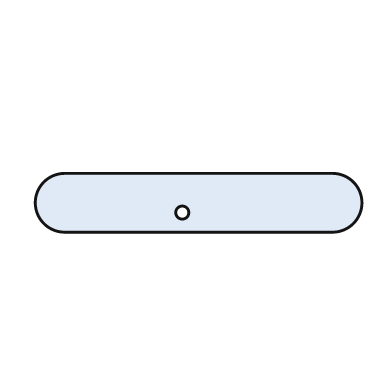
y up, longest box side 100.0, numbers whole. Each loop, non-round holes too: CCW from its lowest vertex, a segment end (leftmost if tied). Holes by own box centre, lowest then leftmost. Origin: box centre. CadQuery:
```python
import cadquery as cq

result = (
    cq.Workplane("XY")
    .moveTo(-41.0, -9.0)
    .lineTo(41.0, -9.0)
    .threePointArc((50.0, 0.0), (41.0, 9.0))
    .lineTo(-41.0, 9.0)
    .threePointArc((-50.0, 0.0), (-41.0, -9.0))
    .close()
    .moveTo(-5.0, -3.0)
    .circle(2.0)
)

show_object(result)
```